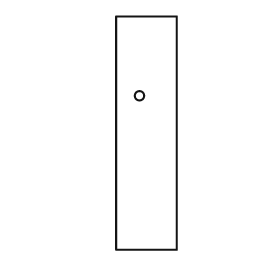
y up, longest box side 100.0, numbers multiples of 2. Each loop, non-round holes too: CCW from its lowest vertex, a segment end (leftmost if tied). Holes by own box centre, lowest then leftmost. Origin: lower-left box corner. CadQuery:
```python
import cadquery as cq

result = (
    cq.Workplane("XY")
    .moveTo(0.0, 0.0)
    .lineTo(26.0, 0.0)
    .lineTo(26.0, 100.0)
    .lineTo(0.0, 100.0)
    .close()
    .moveTo(10.0, 66.0)
    .circle(2.0)
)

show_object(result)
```